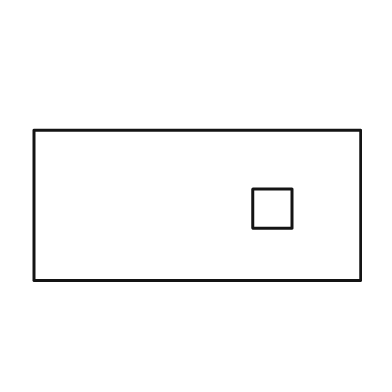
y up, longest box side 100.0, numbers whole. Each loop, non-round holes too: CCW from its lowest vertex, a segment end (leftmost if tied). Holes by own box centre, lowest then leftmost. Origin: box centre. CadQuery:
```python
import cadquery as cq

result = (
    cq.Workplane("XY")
    .moveTo(-50.0, -23.0)
    .lineTo(50.0, -23.0)
    .lineTo(50.0, 23.0)
    .lineTo(-50.0, 23.0)
    .close()
    .moveTo(17.0, -7.0)
    .lineTo(29.0, -7.0)
    .lineTo(29.0, 5.0)
    .lineTo(17.0, 5.0)
    .close()
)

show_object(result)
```